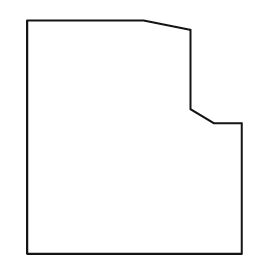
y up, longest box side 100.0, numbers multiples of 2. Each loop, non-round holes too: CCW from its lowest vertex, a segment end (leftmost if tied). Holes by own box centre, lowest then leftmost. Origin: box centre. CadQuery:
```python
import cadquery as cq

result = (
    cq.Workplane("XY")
    .moveTo(-46.0, -50.0)
    .lineTo(46.0, -50.0)
    .lineTo(46.0, 6.0)
    .lineTo(34.0, 6.0)
    .lineTo(24.0, 12.0)
    .lineTo(24.0, 46.0)
    .lineTo(4.0, 50.0)
    .lineTo(-46.0, 50.0)
    .close()
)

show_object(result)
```